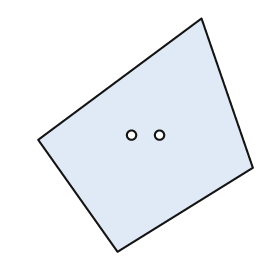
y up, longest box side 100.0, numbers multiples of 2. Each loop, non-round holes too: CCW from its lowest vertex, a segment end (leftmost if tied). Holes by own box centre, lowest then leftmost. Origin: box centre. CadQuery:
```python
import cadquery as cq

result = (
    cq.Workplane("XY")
    .moveTo(-12.0, -50.0)
    .lineTo(46.0, -14.0)
    .lineTo(24.0, 50.0)
    .lineTo(-46.0, -2.0)
    .close()
    .moveTo(-6.0, 0.0)
    .circle(2.0)
    .moveTo(6.0, 0.0)
    .circle(2.0)
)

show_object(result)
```